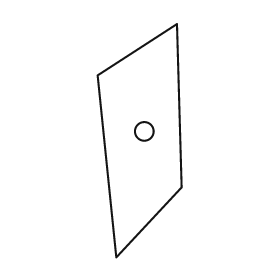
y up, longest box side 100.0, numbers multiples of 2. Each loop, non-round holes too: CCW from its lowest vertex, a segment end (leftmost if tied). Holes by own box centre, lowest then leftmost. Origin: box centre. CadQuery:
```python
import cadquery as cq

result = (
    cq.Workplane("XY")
    .moveTo(-10.0, -50.0)
    .lineTo(18.0, -20.0)
    .lineTo(16.0, 50.0)
    .lineTo(-18.0, 28.0)
    .close()
    .moveTo(2.0, 4.0)
    .circle(4.0)
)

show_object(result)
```